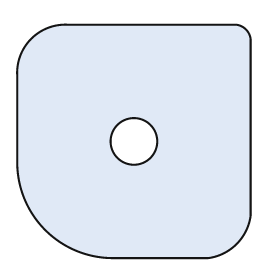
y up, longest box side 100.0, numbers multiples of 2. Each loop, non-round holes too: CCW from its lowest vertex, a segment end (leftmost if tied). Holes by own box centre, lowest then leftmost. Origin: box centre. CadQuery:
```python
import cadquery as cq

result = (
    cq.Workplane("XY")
    .moveTo(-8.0, -50.0)
    .lineTo(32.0, -50.0)
    .threePointArc((44.0, -44.0), (50.0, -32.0))
    .lineTo(50.0, 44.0)
    .threePointArc((48.0, 48.0), (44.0, 50.0))
    .lineTo(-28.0, 50.0)
    .threePointArc((-44.0, 44.0), (-50.0, 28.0))
    .lineTo(-50.0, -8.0)
    .threePointArc((-38.0, -38.0), (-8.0, -50.0))
    .close()
    .moveTo(0.0, 0.0)
    .circle(10.0)
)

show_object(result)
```